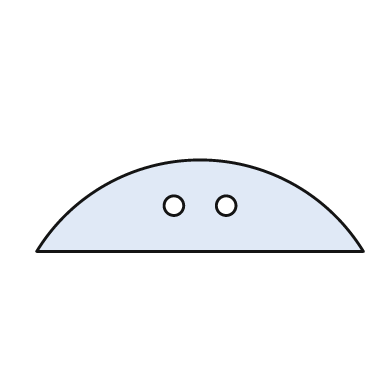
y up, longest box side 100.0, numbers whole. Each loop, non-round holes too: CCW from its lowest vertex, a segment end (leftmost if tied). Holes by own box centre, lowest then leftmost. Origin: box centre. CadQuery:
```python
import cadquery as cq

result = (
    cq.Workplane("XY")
    .moveTo(-50.0, -14.0)
    .lineTo(50.0, -14.0)
    .threePointArc((0.0, 14.0), (-50.0, -14.0))
    .close()
    .moveTo(-8.0, 0.0)
    .circle(3.0)
    .moveTo(8.0, 0.0)
    .circle(3.0)
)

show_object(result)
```